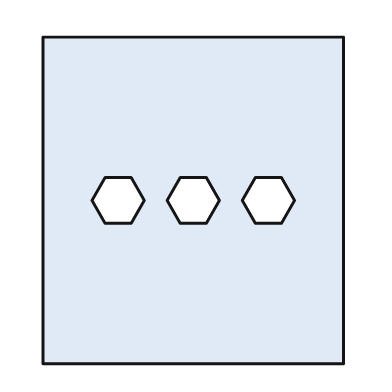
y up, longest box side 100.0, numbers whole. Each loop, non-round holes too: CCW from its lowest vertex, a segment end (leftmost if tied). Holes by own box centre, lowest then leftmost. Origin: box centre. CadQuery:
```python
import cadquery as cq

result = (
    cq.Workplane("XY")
    .moveTo(-46.0, -50.0)
    .lineTo(46.0, -50.0)
    .lineTo(46.0, 50.0)
    .lineTo(-46.0, 50.0)
    .close()
    .moveTo(-27.0, -7.0)
    .lineTo(-19.0, -7.0)
    .lineTo(-15.0, 0.0)
    .lineTo(-19.0, 7.0)
    .lineTo(-27.0, 7.0)
    .lineTo(-31.0, 0.0)
    .close()
    .moveTo(-4.0, -7.0)
    .lineTo(4.0, -7.0)
    .lineTo(8.0, 0.0)
    .lineTo(4.0, 7.0)
    .lineTo(-4.0, 7.0)
    .lineTo(-8.0, 0.0)
    .close()
    .moveTo(19.0, -7.0)
    .lineTo(27.0, -7.0)
    .lineTo(31.0, 0.0)
    .lineTo(27.0, 7.0)
    .lineTo(19.0, 7.0)
    .lineTo(15.0, 0.0)
    .close()
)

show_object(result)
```